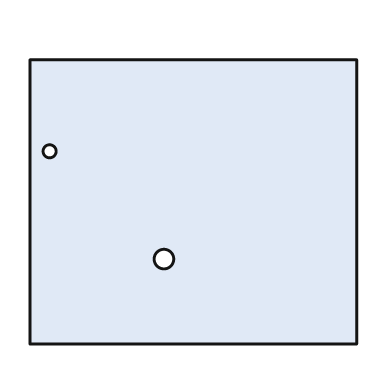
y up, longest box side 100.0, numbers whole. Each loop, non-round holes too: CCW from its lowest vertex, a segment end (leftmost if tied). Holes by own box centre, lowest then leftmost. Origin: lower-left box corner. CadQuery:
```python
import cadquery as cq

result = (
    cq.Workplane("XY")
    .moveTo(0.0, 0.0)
    .lineTo(100.0, 0.0)
    .lineTo(100.0, 87.0)
    .lineTo(0.0, 87.0)
    .close()
    .moveTo(41.0, 26.0)
    .circle(3.0)
    .moveTo(6.0, 59.0)
    .circle(2.0)
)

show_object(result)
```